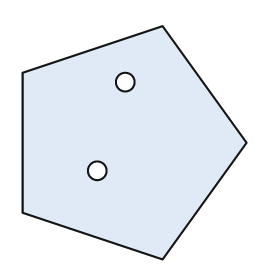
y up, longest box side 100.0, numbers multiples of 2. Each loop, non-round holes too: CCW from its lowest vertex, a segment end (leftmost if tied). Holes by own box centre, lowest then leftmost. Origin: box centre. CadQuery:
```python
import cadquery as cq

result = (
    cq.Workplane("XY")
    .moveTo(12.0, -50.0)
    .lineTo(48.0, 0.0)
    .lineTo(12.0, 50.0)
    .lineTo(-48.0, 30.0)
    .lineTo(-48.0, -30.0)
    .close()
    .moveTo(-16.0, -12.0)
    .circle(4.0)
    .moveTo(-4.0, 26.0)
    .circle(4.0)
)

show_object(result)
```